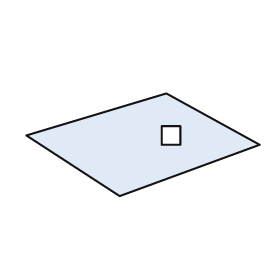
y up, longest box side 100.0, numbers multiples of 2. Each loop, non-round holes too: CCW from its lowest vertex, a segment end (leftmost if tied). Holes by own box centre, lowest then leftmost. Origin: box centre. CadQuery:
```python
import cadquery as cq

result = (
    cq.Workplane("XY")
    .moveTo(-10.0, -22.0)
    .lineTo(50.0, 0.0)
    .lineTo(10.0, 22.0)
    .lineTo(-50.0, 4.0)
    .close()
    .moveTo(8.0, 0.0)
    .lineTo(16.0, 0.0)
    .lineTo(16.0, 8.0)
    .lineTo(8.0, 8.0)
    .close()
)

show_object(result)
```